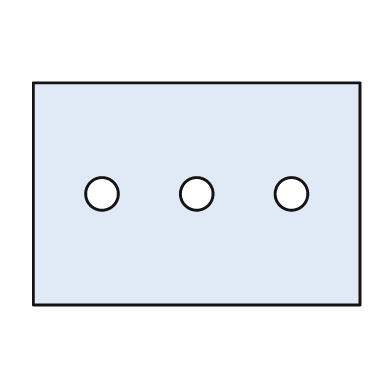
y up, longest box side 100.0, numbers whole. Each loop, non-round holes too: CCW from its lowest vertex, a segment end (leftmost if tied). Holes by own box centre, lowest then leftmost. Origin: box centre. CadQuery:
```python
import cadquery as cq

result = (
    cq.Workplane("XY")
    .moveTo(-50.0, -34.0)
    .lineTo(50.0, -34.0)
    .lineTo(50.0, 34.0)
    .lineTo(-50.0, 34.0)
    .close()
    .moveTo(-29.0, 0.0)
    .circle(5.0)
    .moveTo(0.0, 0.0)
    .circle(5.0)
    .moveTo(29.0, 0.0)
    .circle(5.0)
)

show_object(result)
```